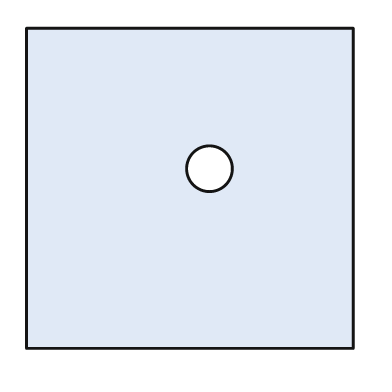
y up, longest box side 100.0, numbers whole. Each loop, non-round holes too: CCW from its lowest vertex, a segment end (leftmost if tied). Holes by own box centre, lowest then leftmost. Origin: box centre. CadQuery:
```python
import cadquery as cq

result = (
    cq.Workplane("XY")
    .moveTo(-50.0, -49.0)
    .lineTo(50.0, -49.0)
    .lineTo(50.0, 49.0)
    .lineTo(-50.0, 49.0)
    .close()
    .moveTo(6.0, 6.0)
    .circle(7.0)
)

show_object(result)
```